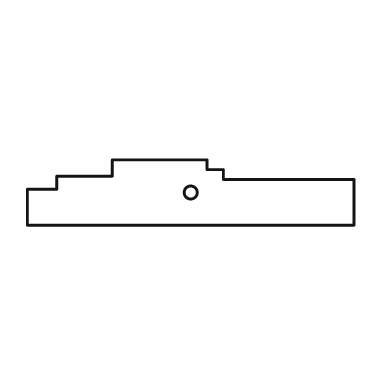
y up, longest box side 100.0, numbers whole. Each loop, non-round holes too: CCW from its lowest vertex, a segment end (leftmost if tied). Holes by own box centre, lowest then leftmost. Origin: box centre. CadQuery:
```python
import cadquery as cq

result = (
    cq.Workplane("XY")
    .moveTo(-50.0, -10.0)
    .lineTo(50.0, -10.0)
    .lineTo(50.0, 4.0)
    .lineTo(10.0, 4.0)
    .lineTo(10.0, 7.0)
    .lineTo(5.0, 7.0)
    .lineTo(5.0, 10.0)
    .lineTo(-24.0, 10.0)
    .lineTo(-24.0, 5.0)
    .lineTo(-41.0, 5.0)
    .lineTo(-41.0, 1.0)
    .lineTo(-50.0, 1.0)
    .close()
    .moveTo(0.0, 0.0)
    .circle(2.0)
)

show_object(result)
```